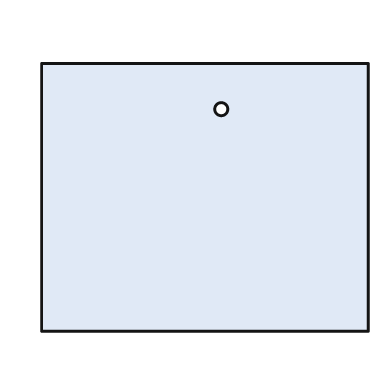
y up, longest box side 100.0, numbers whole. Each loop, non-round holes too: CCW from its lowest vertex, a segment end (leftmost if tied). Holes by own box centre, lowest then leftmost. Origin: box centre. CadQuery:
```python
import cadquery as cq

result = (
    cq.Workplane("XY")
    .moveTo(-50.0, -41.0)
    .lineTo(50.0, -41.0)
    .lineTo(50.0, 41.0)
    .lineTo(-50.0, 41.0)
    .close()
    .moveTo(5.0, 27.0)
    .circle(2.0)
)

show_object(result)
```